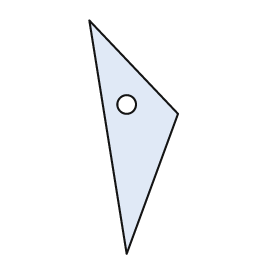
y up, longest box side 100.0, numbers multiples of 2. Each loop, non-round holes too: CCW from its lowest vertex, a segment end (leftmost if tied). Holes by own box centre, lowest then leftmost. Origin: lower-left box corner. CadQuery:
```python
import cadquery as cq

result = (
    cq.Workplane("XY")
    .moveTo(16.0, 0.0)
    .lineTo(38.0, 60.0)
    .lineTo(0.0, 100.0)
    .close()
    .moveTo(16.0, 64.0)
    .circle(4.0)
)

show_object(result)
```